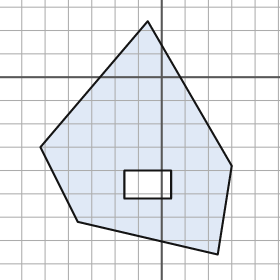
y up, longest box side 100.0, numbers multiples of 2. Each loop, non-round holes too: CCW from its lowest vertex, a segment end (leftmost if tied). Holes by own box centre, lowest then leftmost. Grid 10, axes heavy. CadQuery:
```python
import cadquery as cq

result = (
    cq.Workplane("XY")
    .moveTo(24.0, -76.0)
    .lineTo(30.0, -38.0)
    .lineTo(-6.0, 24.0)
    .lineTo(-52.0, -30.0)
    .lineTo(-36.0, -62.0)
    .close()
    .moveTo(-16.0, -52.0)
    .lineTo(4.0, -52.0)
    .lineTo(4.0, -40.0)
    .lineTo(-16.0, -40.0)
    .close()
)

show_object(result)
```